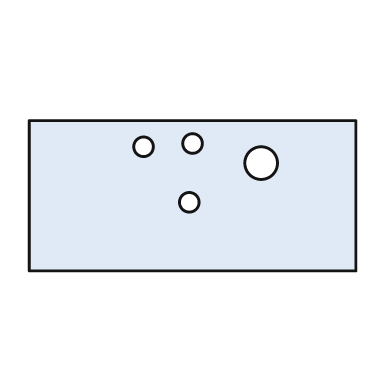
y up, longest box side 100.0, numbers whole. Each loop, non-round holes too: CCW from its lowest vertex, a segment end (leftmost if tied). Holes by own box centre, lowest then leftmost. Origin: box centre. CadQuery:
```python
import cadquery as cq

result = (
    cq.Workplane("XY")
    .moveTo(-50.0, -23.0)
    .lineTo(50.0, -23.0)
    .lineTo(50.0, 23.0)
    .lineTo(-50.0, 23.0)
    .close()
    .moveTo(-1.0, -2.0)
    .circle(3.0)
    .moveTo(21.0, 10.0)
    .circle(5.0)
    .moveTo(-15.0, 15.0)
    .circle(3.0)
    .moveTo(0.0, 16.0)
    .circle(3.0)
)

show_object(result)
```